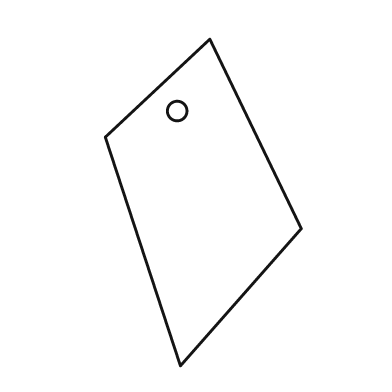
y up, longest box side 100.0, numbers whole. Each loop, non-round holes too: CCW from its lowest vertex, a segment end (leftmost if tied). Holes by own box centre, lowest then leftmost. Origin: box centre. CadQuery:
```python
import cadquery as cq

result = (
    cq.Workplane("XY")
    .moveTo(-7.0, -50.0)
    .lineTo(30.0, -8.0)
    .lineTo(2.0, 50.0)
    .lineTo(-30.0, 20.0)
    .close()
    .moveTo(-8.0, 28.0)
    .circle(3.0)
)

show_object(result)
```